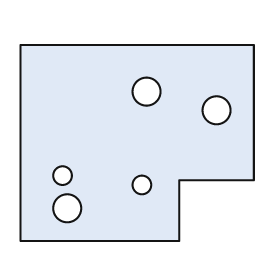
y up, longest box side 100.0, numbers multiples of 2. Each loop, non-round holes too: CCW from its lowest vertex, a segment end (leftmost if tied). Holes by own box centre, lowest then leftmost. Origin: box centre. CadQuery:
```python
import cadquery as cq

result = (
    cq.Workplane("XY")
    .moveTo(-50.0, -42.0)
    .lineTo(18.0, -42.0)
    .lineTo(18.0, -16.0)
    .lineTo(50.0, -16.0)
    .lineTo(50.0, 42.0)
    .lineTo(-50.0, 42.0)
    .close()
    .moveTo(-30.0, -28.0)
    .circle(6.0)
    .moveTo(2.0, -18.0)
    .circle(4.0)
    .moveTo(-32.0, -14.0)
    .circle(4.0)
    .moveTo(34.0, 14.0)
    .circle(6.0)
    .moveTo(4.0, 22.0)
    .circle(6.0)
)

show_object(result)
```